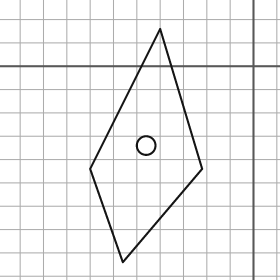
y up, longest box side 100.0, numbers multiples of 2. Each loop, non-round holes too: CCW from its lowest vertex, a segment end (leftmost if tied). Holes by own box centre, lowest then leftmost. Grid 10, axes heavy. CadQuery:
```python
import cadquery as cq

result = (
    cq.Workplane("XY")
    .moveTo(-56.0, -84.0)
    .lineTo(-22.0, -44.0)
    .lineTo(-40.0, 16.0)
    .lineTo(-70.0, -44.0)
    .close()
    .moveTo(-46.0, -34.0)
    .circle(4.0)
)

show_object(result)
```